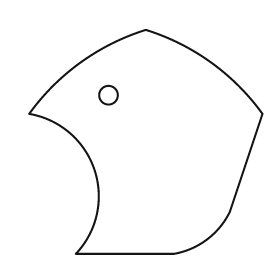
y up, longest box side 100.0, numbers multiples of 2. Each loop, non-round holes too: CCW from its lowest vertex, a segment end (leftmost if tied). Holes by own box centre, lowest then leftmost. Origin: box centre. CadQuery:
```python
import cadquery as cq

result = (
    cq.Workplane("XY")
    .moveTo(-30.0, -48.0)
    .lineTo(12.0, -48.0)
    .threePointArc((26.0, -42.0), (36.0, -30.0))
    .lineTo(50.0, 12.0)
    .threePointArc((28.0, 34.0), (0.0, 48.0))
    .threePointArc((-28.0, 34.0), (-50.0, 12.0))
    .threePointArc((-22.0, -12.0), (-30.0, -48.0))
    .close()
    .moveTo(-16.0, 20.0)
    .circle(4.0)
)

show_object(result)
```